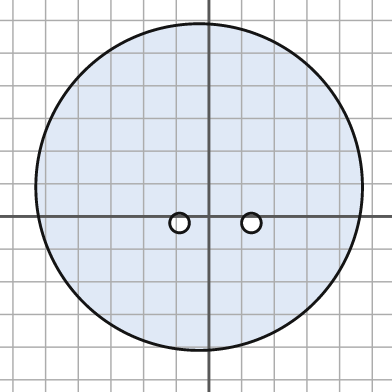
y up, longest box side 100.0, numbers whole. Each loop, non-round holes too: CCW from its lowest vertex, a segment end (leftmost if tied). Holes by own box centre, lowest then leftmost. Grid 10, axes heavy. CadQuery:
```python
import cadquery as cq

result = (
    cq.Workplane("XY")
    .moveTo(-3.0, 9.0)
    .circle(50.0)
    .moveTo(-9.0, -2.0)
    .circle(3.0)
    .moveTo(13.0, -2.0)
    .circle(3.0)
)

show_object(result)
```